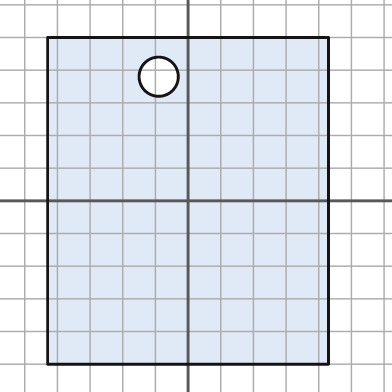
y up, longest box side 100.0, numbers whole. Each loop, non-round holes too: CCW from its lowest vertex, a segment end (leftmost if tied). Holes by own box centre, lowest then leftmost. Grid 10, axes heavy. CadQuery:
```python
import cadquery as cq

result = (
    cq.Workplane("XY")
    .moveTo(-43.0, -50.0)
    .lineTo(43.0, -50.0)
    .lineTo(43.0, 50.0)
    .lineTo(-43.0, 50.0)
    .close()
    .moveTo(-9.0, 38.0)
    .circle(6.0)
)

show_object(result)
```